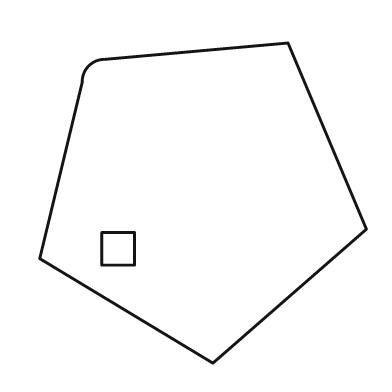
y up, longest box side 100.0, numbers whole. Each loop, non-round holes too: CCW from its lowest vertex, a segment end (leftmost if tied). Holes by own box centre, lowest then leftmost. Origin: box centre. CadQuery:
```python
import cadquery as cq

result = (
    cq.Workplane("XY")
    .moveTo(3.0, -49.0)
    .lineTo(50.0, -8.0)
    .lineTo(26.0, 49.0)
    .lineTo(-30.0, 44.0)
    .threePointArc((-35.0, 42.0), (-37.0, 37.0))
    .lineTo(-50.0, -17.0)
    .close()
    .moveTo(-31.0, -19.0)
    .lineTo(-21.0, -19.0)
    .lineTo(-21.0, -9.0)
    .lineTo(-31.0, -9.0)
    .close()
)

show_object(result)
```